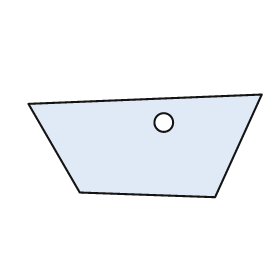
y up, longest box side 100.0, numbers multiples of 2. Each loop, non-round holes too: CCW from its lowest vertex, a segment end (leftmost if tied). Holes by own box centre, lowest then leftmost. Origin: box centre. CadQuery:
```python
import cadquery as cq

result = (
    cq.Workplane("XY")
    .moveTo(30.0, -22.0)
    .lineTo(50.0, 22.0)
    .lineTo(-50.0, 18.0)
    .lineTo(-28.0, -20.0)
    .close()
    .moveTo(8.0, 10.0)
    .circle(4.0)
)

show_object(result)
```